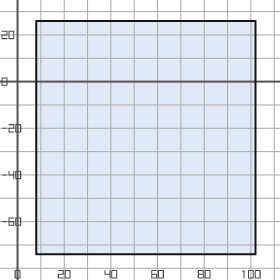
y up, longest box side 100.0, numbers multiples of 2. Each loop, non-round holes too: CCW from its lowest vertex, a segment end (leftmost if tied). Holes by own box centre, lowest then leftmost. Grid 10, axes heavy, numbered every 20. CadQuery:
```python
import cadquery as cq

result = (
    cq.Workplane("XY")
    .moveTo(8.0, -74.0)
    .lineTo(102.0, -74.0)
    .lineTo(102.0, 26.0)
    .lineTo(8.0, 26.0)
    .close()
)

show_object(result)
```